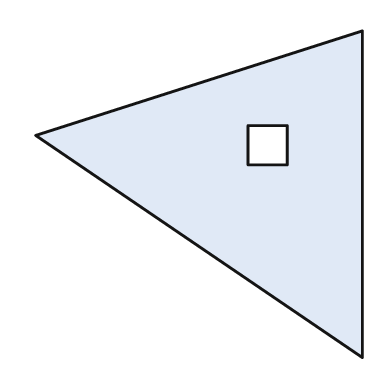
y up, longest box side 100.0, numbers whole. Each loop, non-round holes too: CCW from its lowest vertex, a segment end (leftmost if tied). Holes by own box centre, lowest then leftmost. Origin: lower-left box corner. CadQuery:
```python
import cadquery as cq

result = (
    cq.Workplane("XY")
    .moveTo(100.0, 0.0)
    .lineTo(100.0, 100.0)
    .lineTo(0.0, 68.0)
    .close()
    .moveTo(65.0, 59.0)
    .lineTo(77.0, 59.0)
    .lineTo(77.0, 71.0)
    .lineTo(65.0, 71.0)
    .close()
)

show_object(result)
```